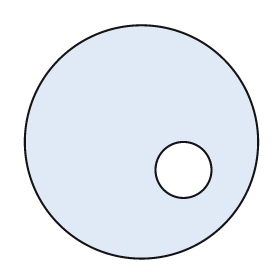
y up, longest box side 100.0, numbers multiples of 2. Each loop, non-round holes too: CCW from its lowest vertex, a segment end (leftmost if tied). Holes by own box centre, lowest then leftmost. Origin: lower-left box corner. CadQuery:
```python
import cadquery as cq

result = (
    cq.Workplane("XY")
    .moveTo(50.0, 50.0)
    .circle(50.0)
    .moveTo(68.0, 38.0)
    .circle(12.0)
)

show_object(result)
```